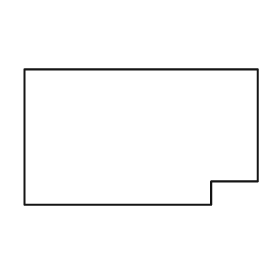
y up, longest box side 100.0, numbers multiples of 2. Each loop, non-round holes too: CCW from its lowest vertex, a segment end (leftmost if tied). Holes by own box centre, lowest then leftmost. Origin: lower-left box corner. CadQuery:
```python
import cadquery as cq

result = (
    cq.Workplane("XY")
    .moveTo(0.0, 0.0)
    .lineTo(80.0, 0.0)
    .lineTo(80.0, 10.0)
    .lineTo(100.0, 10.0)
    .lineTo(100.0, 58.0)
    .lineTo(0.0, 58.0)
    .close()
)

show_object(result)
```